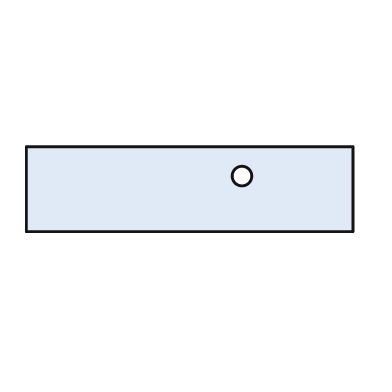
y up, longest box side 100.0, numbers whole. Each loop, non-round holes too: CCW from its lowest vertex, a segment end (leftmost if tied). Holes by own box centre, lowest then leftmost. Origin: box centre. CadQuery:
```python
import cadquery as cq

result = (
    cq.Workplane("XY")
    .moveTo(-50.0, -13.0)
    .lineTo(50.0, -13.0)
    .lineTo(50.0, 13.0)
    .lineTo(-50.0, 13.0)
    .close()
    .moveTo(16.0, 4.0)
    .circle(3.0)
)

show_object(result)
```